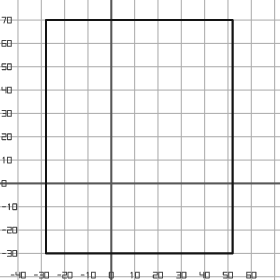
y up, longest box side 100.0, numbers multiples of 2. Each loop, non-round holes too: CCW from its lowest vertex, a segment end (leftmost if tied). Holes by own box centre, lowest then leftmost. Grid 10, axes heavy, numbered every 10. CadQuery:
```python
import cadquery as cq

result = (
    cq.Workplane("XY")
    .moveTo(-28.0, -30.0)
    .lineTo(52.0, -30.0)
    .lineTo(52.0, 70.0)
    .lineTo(-28.0, 70.0)
    .close()
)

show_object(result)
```